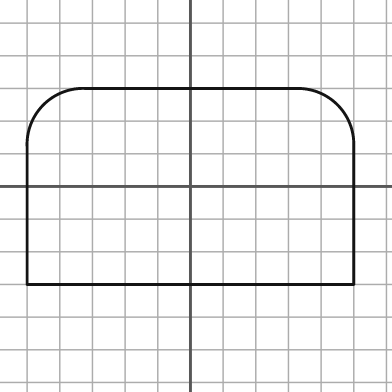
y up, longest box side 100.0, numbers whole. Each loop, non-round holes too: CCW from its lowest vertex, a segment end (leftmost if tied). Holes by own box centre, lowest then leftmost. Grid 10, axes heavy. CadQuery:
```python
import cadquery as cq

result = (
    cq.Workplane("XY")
    .moveTo(-50.0, -30.0)
    .lineTo(50.0, -30.0)
    .lineTo(50.0, 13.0)
    .threePointArc((45.0, 25.0), (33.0, 30.0))
    .lineTo(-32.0, 30.0)
    .threePointArc((-45.0, 25.0), (-50.0, 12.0))
    .close()
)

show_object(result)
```